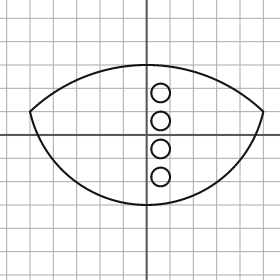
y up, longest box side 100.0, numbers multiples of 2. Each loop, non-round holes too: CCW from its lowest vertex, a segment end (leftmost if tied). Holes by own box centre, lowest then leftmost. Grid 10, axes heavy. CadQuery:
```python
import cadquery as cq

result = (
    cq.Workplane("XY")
    .moveTo(-50.0, 10.0)
    .threePointArc((0.0, -30.0), (50.0, 10.0))
    .threePointArc((0.0, 30.0), (-50.0, 10.0))
    .close()
    .moveTo(6.0, -18.0)
    .circle(4.0)
    .moveTo(6.0, -6.0)
    .circle(4.0)
    .moveTo(6.0, 6.0)
    .circle(4.0)
    .moveTo(6.0, 18.0)
    .circle(4.0)
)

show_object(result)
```